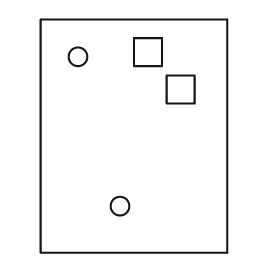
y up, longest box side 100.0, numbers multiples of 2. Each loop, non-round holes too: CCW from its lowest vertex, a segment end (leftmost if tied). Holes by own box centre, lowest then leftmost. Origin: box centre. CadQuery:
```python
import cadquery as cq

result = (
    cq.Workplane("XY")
    .moveTo(-40.0, -50.0)
    .lineTo(40.0, -50.0)
    .lineTo(40.0, 50.0)
    .lineTo(-40.0, 50.0)
    .close()
    .moveTo(-6.0, -30.0)
    .circle(4.0)
    .moveTo(14.0, 14.0)
    .lineTo(26.0, 14.0)
    .lineTo(26.0, 26.0)
    .lineTo(14.0, 26.0)
    .close()
    .moveTo(-24.0, 34.0)
    .circle(4.0)
    .moveTo(0.0, 30.0)
    .lineTo(12.0, 30.0)
    .lineTo(12.0, 42.0)
    .lineTo(0.0, 42.0)
    .close()
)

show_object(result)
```